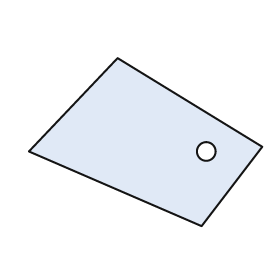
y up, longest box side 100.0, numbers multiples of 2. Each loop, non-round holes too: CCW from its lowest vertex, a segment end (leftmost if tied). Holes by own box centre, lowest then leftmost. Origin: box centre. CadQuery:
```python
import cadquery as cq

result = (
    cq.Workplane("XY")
    .moveTo(24.0, -36.0)
    .lineTo(50.0, -2.0)
    .lineTo(-12.0, 36.0)
    .lineTo(-50.0, -4.0)
    .close()
    .moveTo(26.0, -4.0)
    .circle(4.0)
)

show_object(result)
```